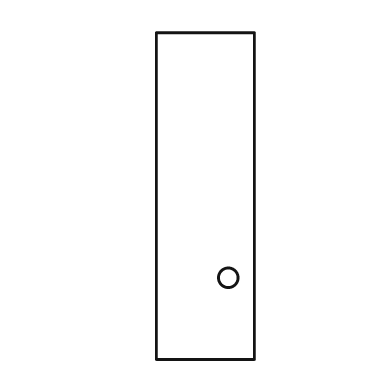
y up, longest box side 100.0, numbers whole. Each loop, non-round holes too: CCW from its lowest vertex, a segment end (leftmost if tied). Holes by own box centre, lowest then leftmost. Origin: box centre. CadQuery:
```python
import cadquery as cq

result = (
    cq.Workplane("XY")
    .moveTo(-15.0, -50.0)
    .lineTo(15.0, -50.0)
    .lineTo(15.0, 50.0)
    .lineTo(-15.0, 50.0)
    .close()
    .moveTo(7.0, -25.0)
    .circle(3.0)
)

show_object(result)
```